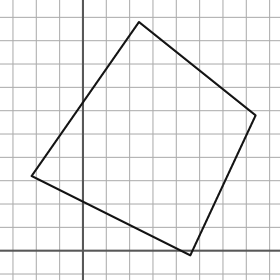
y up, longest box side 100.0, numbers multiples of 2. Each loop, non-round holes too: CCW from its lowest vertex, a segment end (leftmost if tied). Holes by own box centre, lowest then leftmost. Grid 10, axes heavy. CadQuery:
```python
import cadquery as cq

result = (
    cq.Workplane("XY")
    .moveTo(46.0, -2.0)
    .lineTo(74.0, 58.0)
    .lineTo(24.0, 98.0)
    .lineTo(-22.0, 32.0)
    .close()
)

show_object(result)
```